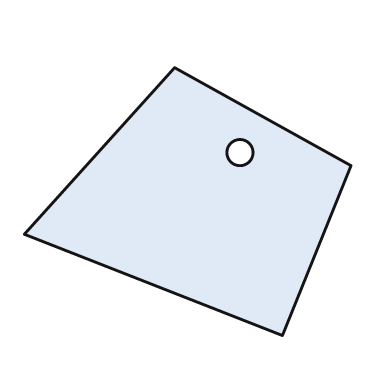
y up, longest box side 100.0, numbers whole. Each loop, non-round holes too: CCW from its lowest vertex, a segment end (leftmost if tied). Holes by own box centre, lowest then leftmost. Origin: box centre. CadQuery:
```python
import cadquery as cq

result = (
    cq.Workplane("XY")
    .moveTo(29.0, -41.0)
    .lineTo(50.0, 11.0)
    .lineTo(-4.0, 41.0)
    .lineTo(-50.0, -10.0)
    .close()
    .moveTo(16.0, 15.0)
    .circle(4.0)
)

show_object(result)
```